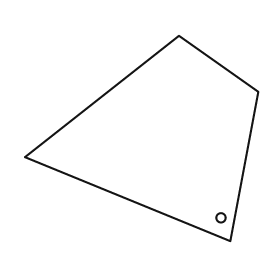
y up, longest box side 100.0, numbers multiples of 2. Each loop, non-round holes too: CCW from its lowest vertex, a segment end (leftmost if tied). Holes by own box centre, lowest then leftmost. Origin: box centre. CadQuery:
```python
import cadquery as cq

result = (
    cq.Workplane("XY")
    .moveTo(38.0, -44.0)
    .lineTo(50.0, 20.0)
    .lineTo(16.0, 44.0)
    .lineTo(-50.0, -8.0)
    .close()
    .moveTo(34.0, -34.0)
    .circle(2.0)
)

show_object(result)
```